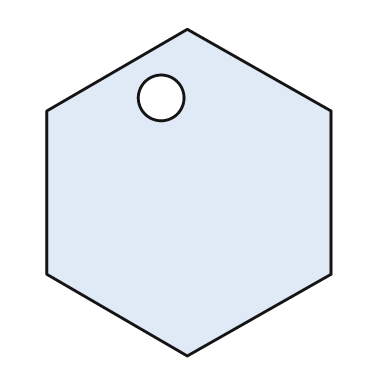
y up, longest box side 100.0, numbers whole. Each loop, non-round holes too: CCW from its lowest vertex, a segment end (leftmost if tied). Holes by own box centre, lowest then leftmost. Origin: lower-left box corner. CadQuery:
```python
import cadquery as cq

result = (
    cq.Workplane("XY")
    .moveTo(43.0, 0.0)
    .lineTo(87.0, 25.0)
    .lineTo(87.0, 75.0)
    .lineTo(43.0, 100.0)
    .lineTo(0.0, 75.0)
    .lineTo(0.0, 25.0)
    .close()
    .moveTo(35.0, 79.0)
    .circle(7.0)
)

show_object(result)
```